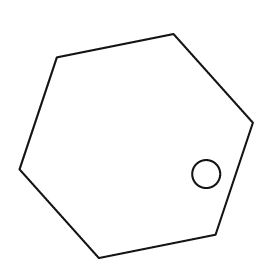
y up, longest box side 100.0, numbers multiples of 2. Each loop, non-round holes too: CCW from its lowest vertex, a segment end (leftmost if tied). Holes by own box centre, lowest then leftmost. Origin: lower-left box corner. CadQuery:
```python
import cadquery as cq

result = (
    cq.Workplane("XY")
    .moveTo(34.0, 0.0)
    .lineTo(84.0, 10.0)
    .lineTo(100.0, 58.0)
    .lineTo(66.0, 96.0)
    .lineTo(16.0, 86.0)
    .lineTo(0.0, 38.0)
    .close()
    .moveTo(80.0, 36.0)
    .circle(6.0)
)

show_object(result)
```